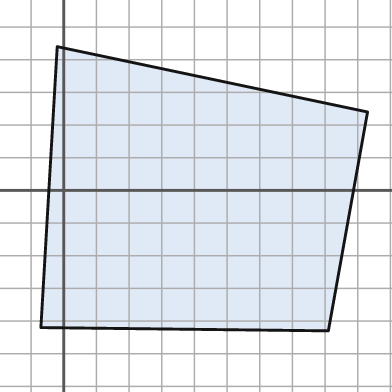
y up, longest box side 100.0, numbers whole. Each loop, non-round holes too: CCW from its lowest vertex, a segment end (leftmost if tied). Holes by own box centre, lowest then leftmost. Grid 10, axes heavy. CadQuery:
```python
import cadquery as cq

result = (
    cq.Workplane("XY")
    .moveTo(81.0, -43.0)
    .lineTo(93.0, 24.0)
    .lineTo(-2.0, 44.0)
    .lineTo(-7.0, -42.0)
    .close()
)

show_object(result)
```